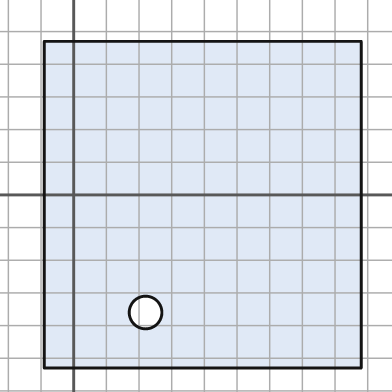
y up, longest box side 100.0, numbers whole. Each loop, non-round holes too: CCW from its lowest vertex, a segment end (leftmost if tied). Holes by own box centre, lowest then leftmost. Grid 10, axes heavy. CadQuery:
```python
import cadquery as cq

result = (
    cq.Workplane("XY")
    .moveTo(-9.0, -53.0)
    .lineTo(88.0, -53.0)
    .lineTo(88.0, 47.0)
    .lineTo(-9.0, 47.0)
    .close()
    .moveTo(22.0, -36.0)
    .circle(5.0)
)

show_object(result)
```